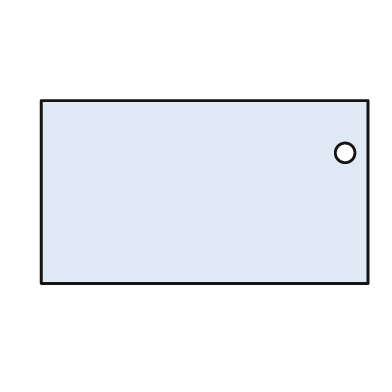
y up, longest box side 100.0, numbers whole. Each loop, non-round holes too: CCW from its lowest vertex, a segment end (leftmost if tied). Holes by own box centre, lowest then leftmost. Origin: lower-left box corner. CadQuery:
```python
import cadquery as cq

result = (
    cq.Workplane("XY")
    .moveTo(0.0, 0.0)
    .lineTo(100.0, 0.0)
    .lineTo(100.0, 56.0)
    .lineTo(0.0, 56.0)
    .close()
    .moveTo(93.0, 40.0)
    .circle(3.0)
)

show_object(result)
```